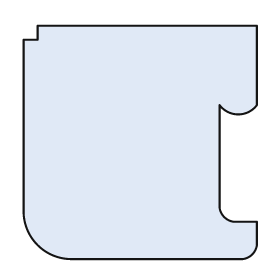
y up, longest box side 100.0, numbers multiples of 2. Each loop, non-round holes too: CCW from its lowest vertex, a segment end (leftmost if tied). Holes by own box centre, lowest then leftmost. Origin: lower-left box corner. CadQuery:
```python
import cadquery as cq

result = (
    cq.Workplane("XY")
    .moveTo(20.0, 0.0)
    .lineTo(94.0, 0.0)
    .threePointArc((98.0, 2.0), (100.0, 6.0))
    .lineTo(100.0, 16.0)
    .lineTo(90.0, 16.0)
    .threePointArc((86.0, 18.0), (84.0, 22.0))
    .lineTo(84.0, 66.0)
    .threePointArc((92.0, 62.0), (100.0, 66.0))
    .lineTo(100.0, 100.0)
    .lineTo(6.0, 100.0)
    .lineTo(6.0, 94.0)
    .lineTo(0.0, 94.0)
    .lineTo(0.0, 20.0)
    .threePointArc((6.0, 6.0), (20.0, 0.0))
    .close()
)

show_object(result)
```